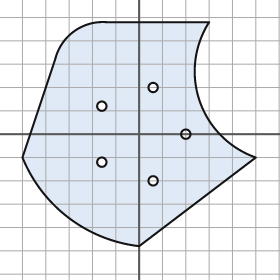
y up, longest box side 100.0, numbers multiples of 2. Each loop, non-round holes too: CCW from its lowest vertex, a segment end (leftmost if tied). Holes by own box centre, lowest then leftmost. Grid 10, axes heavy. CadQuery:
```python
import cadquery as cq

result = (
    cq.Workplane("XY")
    .moveTo(0.0, -48.0)
    .lineTo(50.0, -10.0)
    .threePointArc((26.0, 14.0), (30.0, 48.0))
    .lineTo(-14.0, 48.0)
    .threePointArc((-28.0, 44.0), (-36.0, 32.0))
    .lineTo(-50.0, -10.0)
    .threePointArc((-30.0, -36.0), (0.0, -48.0))
    .close()
    .moveTo(6.0, -20.0)
    .circle(2.0)
    .moveTo(-16.0, -12.0)
    .circle(2.0)
    .moveTo(20.0, 0.0)
    .circle(2.0)
    .moveTo(-16.0, 12.0)
    .circle(2.0)
    .moveTo(6.0, 20.0)
    .circle(2.0)
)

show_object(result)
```